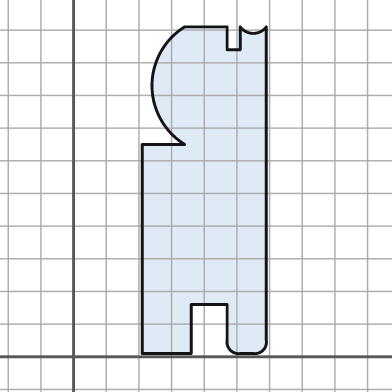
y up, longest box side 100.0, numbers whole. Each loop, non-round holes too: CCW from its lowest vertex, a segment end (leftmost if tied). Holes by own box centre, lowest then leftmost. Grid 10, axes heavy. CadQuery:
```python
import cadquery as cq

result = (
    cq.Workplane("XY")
    .moveTo(21.0, 1.0)
    .lineTo(36.0, 1.0)
    .lineTo(36.0, 16.0)
    .lineTo(47.0, 16.0)
    .lineTo(47.0, 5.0)
    .threePointArc((48.0, 2.0), (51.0, 1.0))
    .lineTo(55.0, 1.0)
    .threePointArc((58.0, 2.0), (59.0, 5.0))
    .lineTo(59.0, 101.0)
    .threePointArc((55.0, 99.0), (51.0, 101.0))
    .lineTo(51.0, 94.0)
    .lineTo(47.0, 94.0)
    .lineTo(47.0, 101.0)
    .lineTo(34.0, 101.0)
    .threePointArc((24.0, 83.0), (34.0, 65.0))
    .lineTo(21.0, 65.0)
    .close()
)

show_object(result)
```